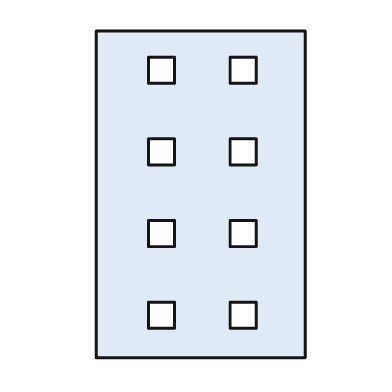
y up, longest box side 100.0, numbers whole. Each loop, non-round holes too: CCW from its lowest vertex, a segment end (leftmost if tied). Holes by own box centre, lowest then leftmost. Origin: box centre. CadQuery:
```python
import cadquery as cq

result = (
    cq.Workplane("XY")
    .moveTo(-32.0, -50.0)
    .lineTo(32.0, -50.0)
    .lineTo(32.0, 50.0)
    .lineTo(-32.0, 50.0)
    .close()
    .moveTo(-16.0, -41.0)
    .lineTo(-8.0, -41.0)
    .lineTo(-8.0, -33.0)
    .lineTo(-16.0, -33.0)
    .close()
    .moveTo(9.0, -41.0)
    .lineTo(17.0, -41.0)
    .lineTo(17.0, -33.0)
    .lineTo(9.0, -33.0)
    .close()
    .moveTo(-16.0, -16.0)
    .lineTo(-8.0, -16.0)
    .lineTo(-8.0, -8.0)
    .lineTo(-16.0, -8.0)
    .close()
    .moveTo(9.0, -16.0)
    .lineTo(17.0, -16.0)
    .lineTo(17.0, -8.0)
    .lineTo(9.0, -8.0)
    .close()
    .moveTo(-16.0, 9.0)
    .lineTo(-8.0, 9.0)
    .lineTo(-8.0, 17.0)
    .lineTo(-16.0, 17.0)
    .close()
    .moveTo(9.0, 9.0)
    .lineTo(17.0, 9.0)
    .lineTo(17.0, 17.0)
    .lineTo(9.0, 17.0)
    .close()
    .moveTo(-16.0, 34.0)
    .lineTo(-8.0, 34.0)
    .lineTo(-8.0, 42.0)
    .lineTo(-16.0, 42.0)
    .close()
    .moveTo(9.0, 34.0)
    .lineTo(17.0, 34.0)
    .lineTo(17.0, 42.0)
    .lineTo(9.0, 42.0)
    .close()
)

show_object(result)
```